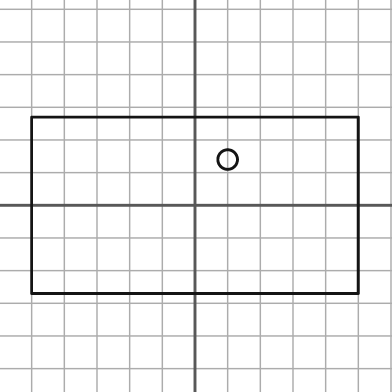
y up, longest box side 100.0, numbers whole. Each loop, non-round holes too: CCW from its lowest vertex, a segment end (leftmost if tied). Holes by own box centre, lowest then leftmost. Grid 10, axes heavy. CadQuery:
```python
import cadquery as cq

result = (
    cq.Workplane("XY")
    .moveTo(-50.0, -27.0)
    .lineTo(50.0, -27.0)
    .lineTo(50.0, 27.0)
    .lineTo(-50.0, 27.0)
    .close()
    .moveTo(10.0, 14.0)
    .circle(3.0)
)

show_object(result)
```